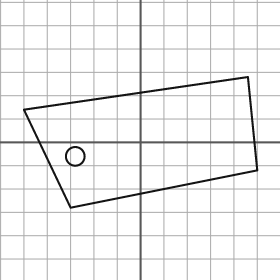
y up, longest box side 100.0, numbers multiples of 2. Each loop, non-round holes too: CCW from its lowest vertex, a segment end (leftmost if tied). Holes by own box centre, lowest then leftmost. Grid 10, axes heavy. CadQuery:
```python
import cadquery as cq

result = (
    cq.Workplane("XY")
    .moveTo(-30.0, -28.0)
    .lineTo(50.0, -12.0)
    .lineTo(46.0, 28.0)
    .lineTo(-50.0, 14.0)
    .close()
    .moveTo(-28.0, -6.0)
    .circle(4.0)
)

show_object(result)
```